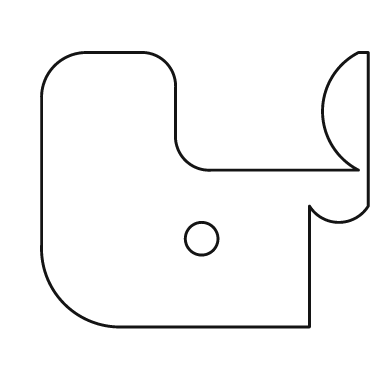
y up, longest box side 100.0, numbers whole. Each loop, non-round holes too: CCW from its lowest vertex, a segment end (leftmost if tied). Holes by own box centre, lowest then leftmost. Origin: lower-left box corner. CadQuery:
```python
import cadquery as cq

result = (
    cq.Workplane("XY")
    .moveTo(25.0, 0.0)
    .lineTo(82.0, 0.0)
    .lineTo(82.0, 37.0)
    .threePointArc((91.0, 32.0), (100.0, 37.0))
    .lineTo(100.0, 84.0)
    .lineTo(97.0, 84.0)
    .threePointArc((86.0, 66.0), (97.0, 48.0))
    .lineTo(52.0, 48.0)
    .threePointArc((44.0, 51.0), (41.0, 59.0))
    .lineTo(41.0, 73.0)
    .threePointArc((38.0, 81.0), (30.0, 84.0))
    .lineTo(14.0, 84.0)
    .threePointArc((4.0, 80.0), (0.0, 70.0))
    .lineTo(0.0, 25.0)
    .threePointArc((7.0, 7.0), (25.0, 0.0))
    .close()
    .moveTo(49.0, 27.0)
    .circle(5.0)
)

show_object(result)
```